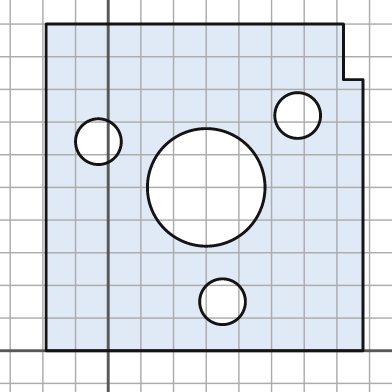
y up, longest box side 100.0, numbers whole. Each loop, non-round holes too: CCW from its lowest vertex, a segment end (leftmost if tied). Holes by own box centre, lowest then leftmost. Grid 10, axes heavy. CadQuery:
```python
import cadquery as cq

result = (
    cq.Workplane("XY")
    .moveTo(-19.0, 0.0)
    .lineTo(78.0, 0.0)
    .lineTo(78.0, 83.0)
    .lineTo(72.0, 83.0)
    .lineTo(72.0, 100.0)
    .lineTo(-19.0, 100.0)
    .close()
    .moveTo(35.0, 15.0)
    .circle(7.0)
    .moveTo(30.0, 50.0)
    .circle(18.0)
    .moveTo(-3.0, 64.0)
    .circle(7.0)
    .moveTo(58.0, 72.0)
    .circle(7.0)
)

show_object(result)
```